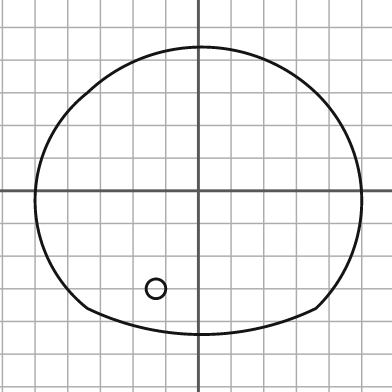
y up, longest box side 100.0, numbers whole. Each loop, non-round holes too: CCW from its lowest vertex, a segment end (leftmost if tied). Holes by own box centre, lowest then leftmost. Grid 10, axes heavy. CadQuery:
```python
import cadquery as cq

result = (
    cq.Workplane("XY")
    .moveTo(-34.0, -36.0)
    .threePointArc((1.0, -44.0), (36.0, -36.0))
    .threePointArc((50.0, -3.0), (36.0, 30.0))
    .threePointArc((1.0, 44.0), (-34.0, 30.0))
    .threePointArc((-50.0, -3.0), (-34.0, -36.0))
    .close()
    .moveTo(-13.0, -30.0)
    .circle(3.0)
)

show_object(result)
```